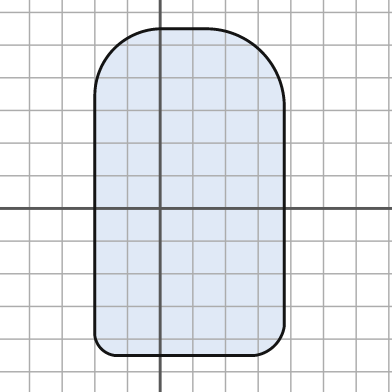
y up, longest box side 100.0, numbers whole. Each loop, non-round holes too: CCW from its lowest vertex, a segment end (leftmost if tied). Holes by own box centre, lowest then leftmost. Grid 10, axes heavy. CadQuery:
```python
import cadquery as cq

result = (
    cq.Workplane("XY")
    .moveTo(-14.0, -45.0)
    .lineTo(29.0, -45.0)
    .threePointArc((35.0, -42.0), (38.0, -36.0))
    .lineTo(38.0, 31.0)
    .threePointArc((31.0, 48.0), (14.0, 55.0))
    .lineTo(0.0, 55.0)
    .threePointArc((-14.0, 49.0), (-20.0, 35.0))
    .lineTo(-20.0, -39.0)
    .threePointArc((-18.0, -43.0), (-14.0, -45.0))
    .close()
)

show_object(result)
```